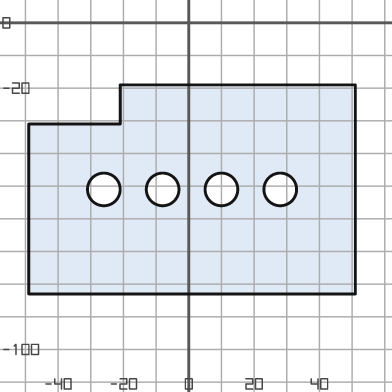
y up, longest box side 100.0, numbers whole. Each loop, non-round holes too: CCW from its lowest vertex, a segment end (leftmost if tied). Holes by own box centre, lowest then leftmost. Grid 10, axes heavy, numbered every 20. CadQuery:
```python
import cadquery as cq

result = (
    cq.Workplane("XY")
    .moveTo(-49.0, -83.0)
    .lineTo(51.0, -83.0)
    .lineTo(51.0, -19.0)
    .lineTo(-21.0, -19.0)
    .lineTo(-21.0, -31.0)
    .lineTo(-49.0, -31.0)
    .close()
    .moveTo(-26.0, -51.0)
    .circle(5.0)
    .moveTo(-8.0, -51.0)
    .circle(5.0)
    .moveTo(10.0, -51.0)
    .circle(5.0)
    .moveTo(28.0, -51.0)
    .circle(5.0)
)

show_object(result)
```